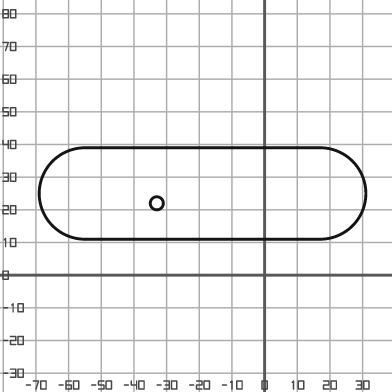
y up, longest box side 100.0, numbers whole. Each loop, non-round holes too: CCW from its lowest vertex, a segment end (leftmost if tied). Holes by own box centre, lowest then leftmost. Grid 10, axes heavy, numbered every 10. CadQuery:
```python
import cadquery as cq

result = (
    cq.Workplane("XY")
    .moveTo(-55.0, 11.0)
    .lineTo(17.0, 11.0)
    .threePointArc((31.0, 25.0), (17.0, 39.0))
    .lineTo(-55.0, 39.0)
    .threePointArc((-69.0, 25.0), (-55.0, 11.0))
    .close()
    .moveTo(-33.0, 22.0)
    .circle(2.0)
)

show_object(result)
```